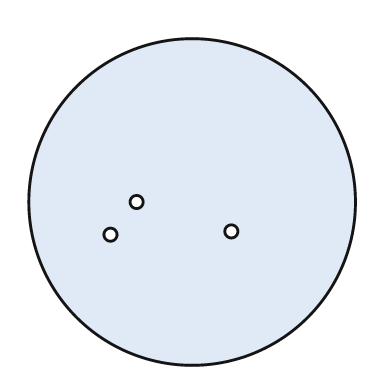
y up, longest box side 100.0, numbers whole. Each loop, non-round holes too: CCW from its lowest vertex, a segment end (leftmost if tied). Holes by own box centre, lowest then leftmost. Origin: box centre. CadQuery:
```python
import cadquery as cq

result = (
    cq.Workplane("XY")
    .moveTo(0.0, 0.0)
    .circle(50.0)
    .moveTo(-25.0, -10.0)
    .circle(2.0)
    .moveTo(12.0, -9.0)
    .circle(2.0)
    .moveTo(-17.0, 0.0)
    .circle(2.0)
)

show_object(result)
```